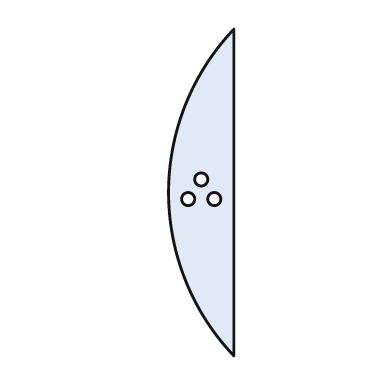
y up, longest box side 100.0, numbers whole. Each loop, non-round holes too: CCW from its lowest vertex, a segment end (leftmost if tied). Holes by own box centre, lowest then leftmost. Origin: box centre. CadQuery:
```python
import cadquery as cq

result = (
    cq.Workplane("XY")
    .moveTo(10.0, -50.0)
    .lineTo(10.0, 50.0)
    .threePointArc((-10.0, 0.0), (10.0, -50.0))
    .close()
    .moveTo(-4.0, -2.0)
    .circle(2.0)
    .moveTo(4.0, -2.0)
    .circle(2.0)
    .moveTo(0.0, 4.0)
    .circle(2.0)
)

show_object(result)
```